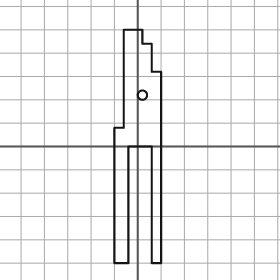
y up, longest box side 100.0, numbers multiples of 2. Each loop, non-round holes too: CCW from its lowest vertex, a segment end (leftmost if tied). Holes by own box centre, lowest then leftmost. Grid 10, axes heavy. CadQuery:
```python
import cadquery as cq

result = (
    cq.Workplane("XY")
    .moveTo(-10.0, -50.0)
    .lineTo(-4.0, -50.0)
    .lineTo(-4.0, 0.0)
    .lineTo(6.0, 0.0)
    .lineTo(6.0, -50.0)
    .lineTo(10.0, -50.0)
    .lineTo(10.0, 32.0)
    .lineTo(6.0, 32.0)
    .lineTo(6.0, 44.0)
    .lineTo(2.0, 44.0)
    .lineTo(2.0, 50.0)
    .lineTo(-6.0, 50.0)
    .lineTo(-6.0, 8.0)
    .lineTo(-10.0, 8.0)
    .close()
    .moveTo(2.0, 22.0)
    .circle(2.0)
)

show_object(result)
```